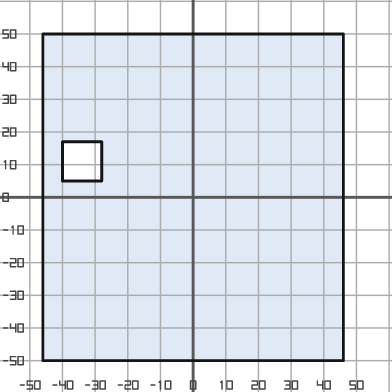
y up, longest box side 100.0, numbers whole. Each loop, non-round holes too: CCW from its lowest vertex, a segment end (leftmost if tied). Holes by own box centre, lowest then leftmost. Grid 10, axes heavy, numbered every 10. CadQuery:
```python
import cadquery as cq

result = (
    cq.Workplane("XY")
    .moveTo(-46.0, -50.0)
    .lineTo(46.0, -50.0)
    .lineTo(46.0, 50.0)
    .lineTo(-46.0, 50.0)
    .close()
    .moveTo(-40.0, 5.0)
    .lineTo(-28.0, 5.0)
    .lineTo(-28.0, 17.0)
    .lineTo(-40.0, 17.0)
    .close()
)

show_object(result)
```